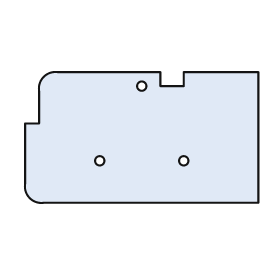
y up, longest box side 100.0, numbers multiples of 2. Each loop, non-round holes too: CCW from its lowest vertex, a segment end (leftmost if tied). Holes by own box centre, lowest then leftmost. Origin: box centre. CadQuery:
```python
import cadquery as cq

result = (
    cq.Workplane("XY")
    .moveTo(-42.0, -28.0)
    .lineTo(50.0, -28.0)
    .lineTo(50.0, 28.0)
    .lineTo(18.0, 28.0)
    .lineTo(18.0, 22.0)
    .lineTo(8.0, 22.0)
    .lineTo(8.0, 28.0)
    .lineTo(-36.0, 28.0)
    .threePointArc((-42.0, 26.0), (-44.0, 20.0))
    .lineTo(-44.0, 6.0)
    .lineTo(-50.0, 6.0)
    .lineTo(-50.0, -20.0)
    .threePointArc((-48.0, -26.0), (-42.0, -28.0))
    .close()
    .moveTo(-18.0, -10.0)
    .circle(2.0)
    .moveTo(18.0, -10.0)
    .circle(2.0)
    .moveTo(0.0, 22.0)
    .circle(2.0)
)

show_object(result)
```